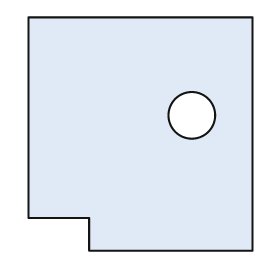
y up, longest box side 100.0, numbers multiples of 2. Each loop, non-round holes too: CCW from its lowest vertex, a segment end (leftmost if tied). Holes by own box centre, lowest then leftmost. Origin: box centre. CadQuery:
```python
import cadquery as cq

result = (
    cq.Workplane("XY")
    .moveTo(-22.0, -50.0)
    .lineTo(48.0, -50.0)
    .lineTo(48.0, 50.0)
    .lineTo(-48.0, 50.0)
    .lineTo(-48.0, -36.0)
    .lineTo(-22.0, -36.0)
    .close()
    .moveTo(22.0, 8.0)
    .circle(10.0)
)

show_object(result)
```